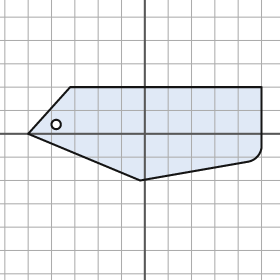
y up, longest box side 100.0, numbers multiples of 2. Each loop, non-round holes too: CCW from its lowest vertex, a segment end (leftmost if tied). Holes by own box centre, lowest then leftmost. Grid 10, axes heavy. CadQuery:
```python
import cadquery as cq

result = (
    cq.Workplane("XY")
    .moveTo(-2.0, -20.0)
    .lineTo(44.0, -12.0)
    .threePointArc((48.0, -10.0), (50.0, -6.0))
    .lineTo(50.0, 20.0)
    .lineTo(-32.0, 20.0)
    .lineTo(-50.0, 0.0)
    .close()
    .moveTo(-38.0, 4.0)
    .circle(2.0)
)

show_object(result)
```